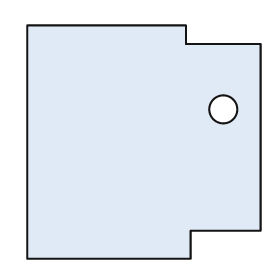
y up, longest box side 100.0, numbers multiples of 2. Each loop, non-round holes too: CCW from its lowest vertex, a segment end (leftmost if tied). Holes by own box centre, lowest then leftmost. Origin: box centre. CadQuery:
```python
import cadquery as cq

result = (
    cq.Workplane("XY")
    .moveTo(-50.0, -50.0)
    .lineTo(20.0, -50.0)
    .lineTo(20.0, -38.0)
    .lineTo(50.0, -38.0)
    .lineTo(50.0, 42.0)
    .lineTo(18.0, 42.0)
    .lineTo(18.0, 50.0)
    .lineTo(-50.0, 50.0)
    .close()
    .moveTo(34.0, 14.0)
    .circle(6.0)
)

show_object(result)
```